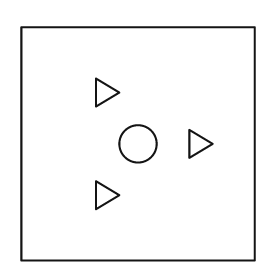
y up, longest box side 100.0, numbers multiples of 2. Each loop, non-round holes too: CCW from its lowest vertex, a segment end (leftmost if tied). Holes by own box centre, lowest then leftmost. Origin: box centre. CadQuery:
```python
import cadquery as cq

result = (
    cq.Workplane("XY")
    .moveTo(-50.0, -50.0)
    .lineTo(50.0, -50.0)
    .lineTo(50.0, 50.0)
    .lineTo(-50.0, 50.0)
    .close()
    .moveTo(-18.0, -28.0)
    .lineTo(-8.0, -22.0)
    .lineTo(-18.0, -16.0)
    .close()
    .moveTo(0.0, 0.0)
    .circle(8.0)
    .moveTo(22.0, -6.0)
    .lineTo(32.0, 0.0)
    .lineTo(22.0, 6.0)
    .close()
    .moveTo(-18.0, 16.0)
    .lineTo(-8.0, 22.0)
    .lineTo(-18.0, 28.0)
    .close()
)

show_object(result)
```